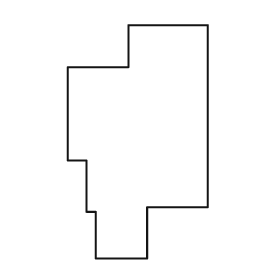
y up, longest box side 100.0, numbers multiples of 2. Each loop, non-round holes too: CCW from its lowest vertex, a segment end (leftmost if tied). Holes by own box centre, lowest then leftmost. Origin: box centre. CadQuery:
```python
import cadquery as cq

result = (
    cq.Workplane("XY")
    .moveTo(-18.0, -50.0)
    .lineTo(4.0, -50.0)
    .lineTo(4.0, -28.0)
    .lineTo(30.0, -28.0)
    .lineTo(30.0, 50.0)
    .lineTo(-4.0, 50.0)
    .lineTo(-4.0, 32.0)
    .lineTo(-30.0, 32.0)
    .lineTo(-30.0, -8.0)
    .lineTo(-22.0, -8.0)
    .lineTo(-22.0, -30.0)
    .lineTo(-18.0, -30.0)
    .close()
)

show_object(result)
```